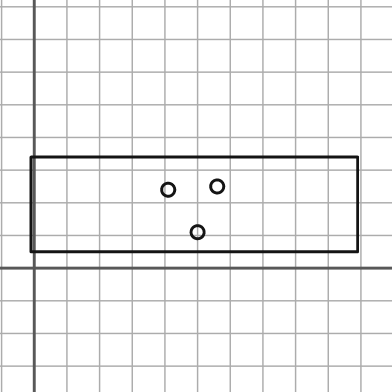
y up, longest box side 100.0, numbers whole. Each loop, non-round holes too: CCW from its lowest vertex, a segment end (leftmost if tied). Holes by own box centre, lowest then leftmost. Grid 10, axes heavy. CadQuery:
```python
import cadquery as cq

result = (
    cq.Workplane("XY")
    .moveTo(-1.0, 5.0)
    .lineTo(99.0, 5.0)
    .lineTo(99.0, 34.0)
    .lineTo(-1.0, 34.0)
    .close()
    .moveTo(50.0, 11.0)
    .circle(2.0)
    .moveTo(41.0, 24.0)
    .circle(2.0)
    .moveTo(56.0, 25.0)
    .circle(2.0)
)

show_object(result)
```